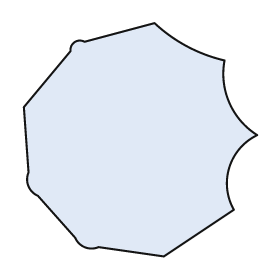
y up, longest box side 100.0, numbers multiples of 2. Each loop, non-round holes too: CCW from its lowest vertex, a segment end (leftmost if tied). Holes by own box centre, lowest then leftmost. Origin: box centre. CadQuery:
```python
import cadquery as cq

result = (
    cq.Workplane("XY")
    .moveTo(10.0, -50.0)
    .lineTo(40.0, -30.0)
    .threePointArc((38.0, -12.0), (50.0, 2.0))
    .threePointArc((38.0, 16.0), (36.0, 34.0))
    .threePointArc((20.0, 40.0), (6.0, 50.0))
    .lineTo(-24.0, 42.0)
    .threePointArc((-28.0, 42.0), (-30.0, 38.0))
    .lineTo(-50.0, 14.0)
    .lineTo(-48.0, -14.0)
    .threePointArc((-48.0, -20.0), (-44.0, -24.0))
    .lineTo(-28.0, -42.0)
    .threePointArc((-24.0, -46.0), (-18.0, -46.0))
    .close()
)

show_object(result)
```